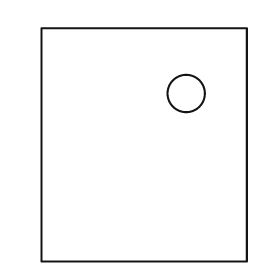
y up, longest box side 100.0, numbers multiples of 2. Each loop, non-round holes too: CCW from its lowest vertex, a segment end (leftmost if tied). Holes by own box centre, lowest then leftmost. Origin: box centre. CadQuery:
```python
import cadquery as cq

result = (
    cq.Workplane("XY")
    .moveTo(-44.0, -50.0)
    .lineTo(44.0, -50.0)
    .lineTo(44.0, 50.0)
    .lineTo(-44.0, 50.0)
    .close()
    .moveTo(18.0, 22.0)
    .circle(8.0)
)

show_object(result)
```